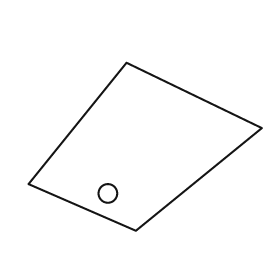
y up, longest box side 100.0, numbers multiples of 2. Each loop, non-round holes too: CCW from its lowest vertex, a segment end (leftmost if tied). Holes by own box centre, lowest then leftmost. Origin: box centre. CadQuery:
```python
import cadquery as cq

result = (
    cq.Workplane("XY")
    .moveTo(-4.0, -36.0)
    .lineTo(50.0, 8.0)
    .lineTo(-8.0, 36.0)
    .lineTo(-50.0, -16.0)
    .close()
    .moveTo(-16.0, -20.0)
    .circle(4.0)
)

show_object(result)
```